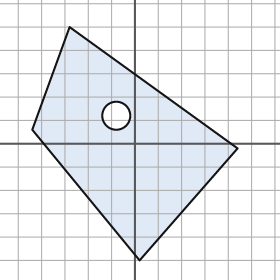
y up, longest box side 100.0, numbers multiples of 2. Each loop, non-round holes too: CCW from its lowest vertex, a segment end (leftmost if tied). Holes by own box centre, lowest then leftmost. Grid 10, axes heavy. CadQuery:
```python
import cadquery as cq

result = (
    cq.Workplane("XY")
    .moveTo(2.0, -50.0)
    .lineTo(44.0, -2.0)
    .lineTo(-28.0, 50.0)
    .lineTo(-44.0, 6.0)
    .close()
    .moveTo(-8.0, 12.0)
    .circle(6.0)
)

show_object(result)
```